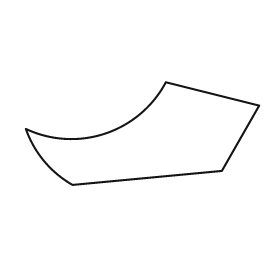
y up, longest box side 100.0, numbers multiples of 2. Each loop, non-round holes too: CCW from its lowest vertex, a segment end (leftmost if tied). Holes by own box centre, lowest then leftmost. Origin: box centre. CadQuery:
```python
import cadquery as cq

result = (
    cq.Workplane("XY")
    .moveTo(-30.0, -22.0)
    .lineTo(34.0, -16.0)
    .lineTo(50.0, 12.0)
    .lineTo(10.0, 22.0)
    .threePointArc((-16.0, 0.0), (-50.0, 2.0))
    .threePointArc((-42.0, -12.0), (-30.0, -22.0))
    .close()
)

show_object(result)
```